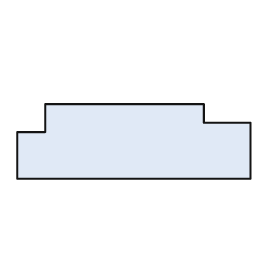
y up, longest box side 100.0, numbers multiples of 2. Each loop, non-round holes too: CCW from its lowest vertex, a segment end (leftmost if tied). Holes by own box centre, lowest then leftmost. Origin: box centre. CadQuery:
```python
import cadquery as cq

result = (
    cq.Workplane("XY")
    .moveTo(-50.0, -16.0)
    .lineTo(50.0, -16.0)
    .lineTo(50.0, 8.0)
    .lineTo(30.0, 8.0)
    .lineTo(30.0, 16.0)
    .lineTo(-38.0, 16.0)
    .lineTo(-38.0, 4.0)
    .lineTo(-50.0, 4.0)
    .close()
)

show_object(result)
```